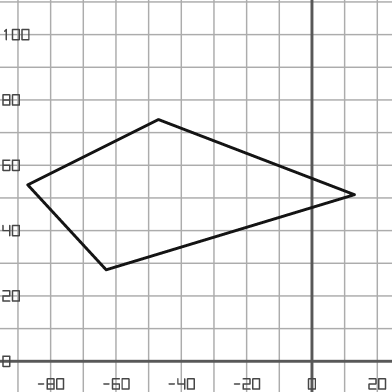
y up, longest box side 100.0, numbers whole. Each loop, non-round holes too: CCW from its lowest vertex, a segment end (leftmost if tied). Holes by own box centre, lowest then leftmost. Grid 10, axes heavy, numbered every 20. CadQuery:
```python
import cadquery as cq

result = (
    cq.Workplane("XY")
    .moveTo(-63.0, 28.0)
    .lineTo(13.0, 51.0)
    .lineTo(-47.0, 74.0)
    .lineTo(-87.0, 54.0)
    .close()
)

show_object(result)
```